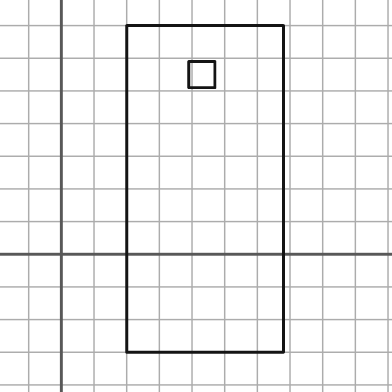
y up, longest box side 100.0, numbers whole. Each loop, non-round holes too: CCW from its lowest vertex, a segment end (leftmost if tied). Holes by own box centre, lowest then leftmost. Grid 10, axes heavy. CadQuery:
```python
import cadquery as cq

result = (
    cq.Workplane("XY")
    .moveTo(20.0, -30.0)
    .lineTo(68.0, -30.0)
    .lineTo(68.0, 70.0)
    .lineTo(20.0, 70.0)
    .close()
    .moveTo(39.0, 51.0)
    .lineTo(47.0, 51.0)
    .lineTo(47.0, 59.0)
    .lineTo(39.0, 59.0)
    .close()
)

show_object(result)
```